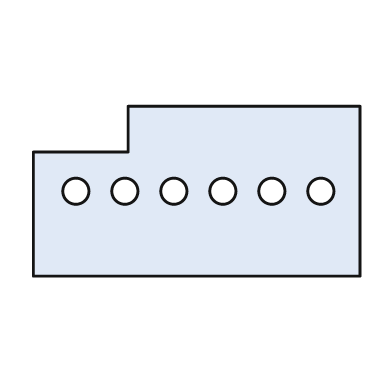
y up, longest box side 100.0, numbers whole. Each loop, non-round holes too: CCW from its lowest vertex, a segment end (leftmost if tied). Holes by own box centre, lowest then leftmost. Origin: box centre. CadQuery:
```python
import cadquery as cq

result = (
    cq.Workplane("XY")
    .moveTo(-50.0, -26.0)
    .lineTo(50.0, -26.0)
    .lineTo(50.0, 26.0)
    .lineTo(-21.0, 26.0)
    .lineTo(-21.0, 12.0)
    .lineTo(-50.0, 12.0)
    .close()
    .moveTo(-37.0, 0.0)
    .circle(4.0)
    .moveTo(-22.0, 0.0)
    .circle(4.0)
    .moveTo(-7.0, 0.0)
    .circle(4.0)
    .moveTo(8.0, 0.0)
    .circle(4.0)
    .moveTo(23.0, 0.0)
    .circle(4.0)
    .moveTo(38.0, 0.0)
    .circle(4.0)
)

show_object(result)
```